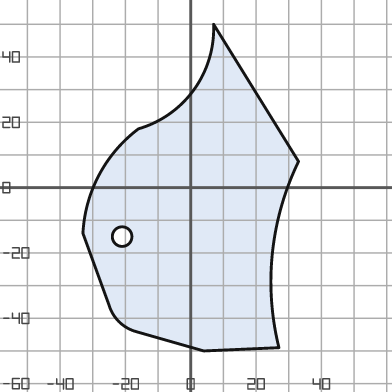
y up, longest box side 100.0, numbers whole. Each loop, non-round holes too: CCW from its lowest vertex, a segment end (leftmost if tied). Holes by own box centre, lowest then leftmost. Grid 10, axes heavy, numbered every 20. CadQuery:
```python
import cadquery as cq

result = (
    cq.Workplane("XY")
    .moveTo(4.0, -50.0)
    .lineTo(27.0, -49.0)
    .threePointArc((25.0, -20.0), (33.0, 8.0))
    .lineTo(7.0, 50.0)
    .threePointArc((1.0, 30.0), (-16.0, 18.0))
    .threePointArc((-28.0, 4.0), (-33.0, -14.0))
    .lineTo(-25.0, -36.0)
    .threePointArc((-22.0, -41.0), (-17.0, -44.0))
    .close()
    .moveTo(-21.0, -15.0)
    .circle(3.0)
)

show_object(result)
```